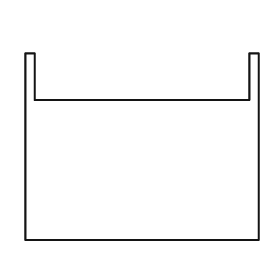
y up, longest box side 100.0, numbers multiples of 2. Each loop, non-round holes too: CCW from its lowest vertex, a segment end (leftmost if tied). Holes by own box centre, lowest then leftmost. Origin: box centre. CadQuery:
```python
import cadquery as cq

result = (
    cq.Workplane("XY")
    .moveTo(-50.0, -40.0)
    .lineTo(50.0, -40.0)
    .lineTo(50.0, 40.0)
    .lineTo(46.0, 40.0)
    .lineTo(46.0, 20.0)
    .lineTo(-46.0, 20.0)
    .lineTo(-46.0, 40.0)
    .lineTo(-50.0, 40.0)
    .close()
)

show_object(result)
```